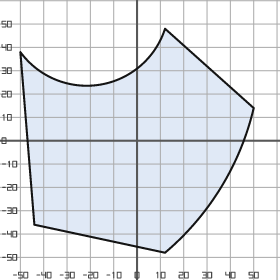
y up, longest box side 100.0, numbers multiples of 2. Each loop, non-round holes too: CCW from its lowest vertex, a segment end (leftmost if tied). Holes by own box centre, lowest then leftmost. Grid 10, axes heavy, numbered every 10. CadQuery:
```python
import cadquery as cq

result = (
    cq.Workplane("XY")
    .moveTo(12.0, -48.0)
    .threePointArc((36.0, -20.0), (50.0, 14.0))
    .lineTo(12.0, 48.0)
    .threePointArc((-16.0, 24.0), (-50.0, 38.0))
    .lineTo(-44.0, -36.0)
    .close()
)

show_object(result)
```